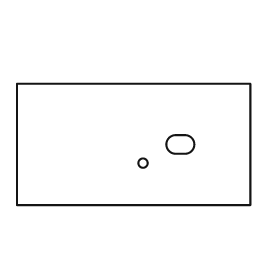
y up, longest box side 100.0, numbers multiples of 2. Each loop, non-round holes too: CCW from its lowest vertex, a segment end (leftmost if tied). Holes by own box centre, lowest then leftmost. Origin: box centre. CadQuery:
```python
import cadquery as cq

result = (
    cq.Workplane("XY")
    .moveTo(-50.0, -26.0)
    .lineTo(50.0, -26.0)
    .lineTo(50.0, 26.0)
    .lineTo(-50.0, 26.0)
    .close()
    .moveTo(4.0, -8.0)
    .circle(2.0)
    .moveTo(18.0, -4.0)
    .lineTo(22.0, -4.0)
    .threePointArc((26.0, 0.0), (22.0, 4.0))
    .lineTo(18.0, 4.0)
    .threePointArc((14.0, 0.0), (18.0, -4.0))
    .close()
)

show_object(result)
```